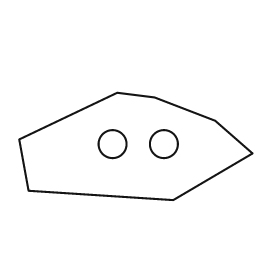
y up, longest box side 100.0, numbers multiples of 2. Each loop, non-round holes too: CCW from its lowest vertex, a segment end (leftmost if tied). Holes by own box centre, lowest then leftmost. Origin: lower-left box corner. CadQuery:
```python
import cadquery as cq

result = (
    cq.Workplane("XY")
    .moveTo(66.0, 0.0)
    .lineTo(100.0, 20.0)
    .lineTo(84.0, 34.0)
    .lineTo(58.0, 44.0)
    .lineTo(42.0, 46.0)
    .lineTo(0.0, 26.0)
    .lineTo(4.0, 4.0)
    .close()
    .moveTo(40.0, 24.0)
    .circle(6.0)
    .moveTo(62.0, 24.0)
    .circle(6.0)
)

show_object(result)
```